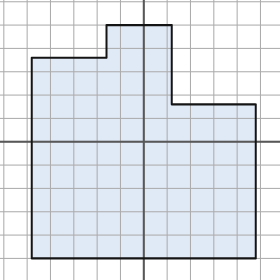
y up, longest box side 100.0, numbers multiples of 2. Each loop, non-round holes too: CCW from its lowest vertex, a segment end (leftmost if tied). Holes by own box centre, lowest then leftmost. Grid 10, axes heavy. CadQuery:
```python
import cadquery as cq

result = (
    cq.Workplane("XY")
    .moveTo(-48.0, -50.0)
    .lineTo(48.0, -50.0)
    .lineTo(48.0, 16.0)
    .lineTo(12.0, 16.0)
    .lineTo(12.0, 50.0)
    .lineTo(-16.0, 50.0)
    .lineTo(-16.0, 36.0)
    .lineTo(-48.0, 36.0)
    .close()
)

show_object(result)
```